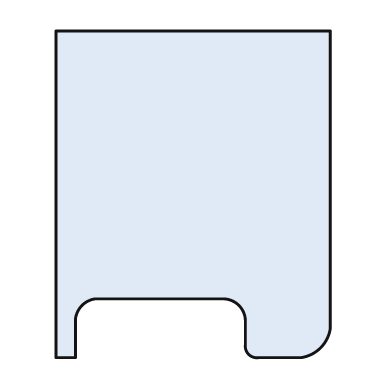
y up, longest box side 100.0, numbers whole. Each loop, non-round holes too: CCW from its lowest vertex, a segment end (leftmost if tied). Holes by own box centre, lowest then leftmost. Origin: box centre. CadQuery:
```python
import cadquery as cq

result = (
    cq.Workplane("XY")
    .moveTo(-42.0, -50.0)
    .lineTo(-36.0, -50.0)
    .lineTo(-36.0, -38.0)
    .threePointArc((-34.0, -34.0), (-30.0, -32.0))
    .lineTo(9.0, -32.0)
    .threePointArc((14.0, -34.0), (16.0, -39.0))
    .lineTo(16.0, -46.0)
    .threePointArc((17.0, -49.0), (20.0, -50.0))
    .lineTo(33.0, -50.0)
    .threePointArc((39.0, -47.0), (42.0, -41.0))
    .lineTo(42.0, 50.0)
    .lineTo(-42.0, 50.0)
    .close()
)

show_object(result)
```